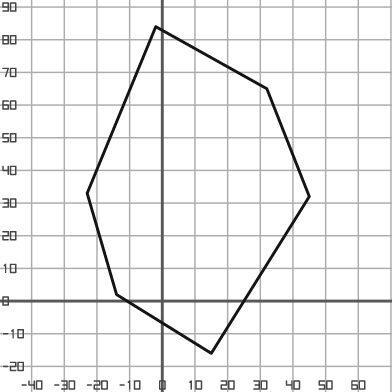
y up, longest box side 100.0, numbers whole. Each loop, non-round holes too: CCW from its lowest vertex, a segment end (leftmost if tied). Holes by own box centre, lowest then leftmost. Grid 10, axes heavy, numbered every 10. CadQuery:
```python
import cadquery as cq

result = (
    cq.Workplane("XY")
    .moveTo(15.0, -16.0)
    .lineTo(45.0, 32.0)
    .lineTo(32.0, 65.0)
    .lineTo(-2.0, 84.0)
    .lineTo(-23.0, 33.0)
    .lineTo(-14.0, 2.0)
    .close()
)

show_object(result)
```